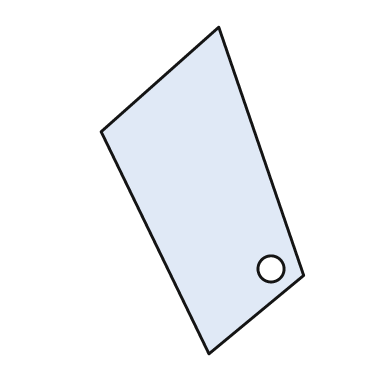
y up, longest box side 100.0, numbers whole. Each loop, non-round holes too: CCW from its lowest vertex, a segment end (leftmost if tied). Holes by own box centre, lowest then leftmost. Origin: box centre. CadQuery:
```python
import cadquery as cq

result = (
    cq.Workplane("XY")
    .moveTo(2.0, -50.0)
    .lineTo(31.0, -26.0)
    .lineTo(5.0, 50.0)
    .lineTo(-31.0, 18.0)
    .close()
    .moveTo(21.0, -24.0)
    .circle(4.0)
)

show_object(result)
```